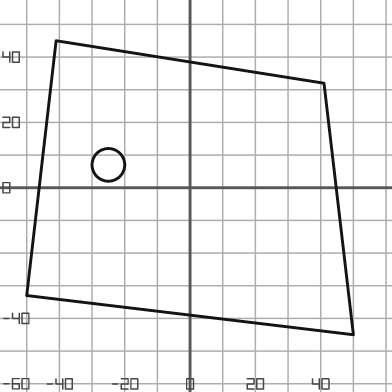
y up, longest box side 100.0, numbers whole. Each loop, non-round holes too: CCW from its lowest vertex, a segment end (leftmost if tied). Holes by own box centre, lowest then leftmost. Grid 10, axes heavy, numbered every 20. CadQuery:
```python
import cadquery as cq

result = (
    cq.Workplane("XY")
    .moveTo(50.0, -45.0)
    .lineTo(41.0, 32.0)
    .lineTo(-41.0, 45.0)
    .lineTo(-50.0, -33.0)
    .close()
    .moveTo(-25.0, 7.0)
    .circle(5.0)
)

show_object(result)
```